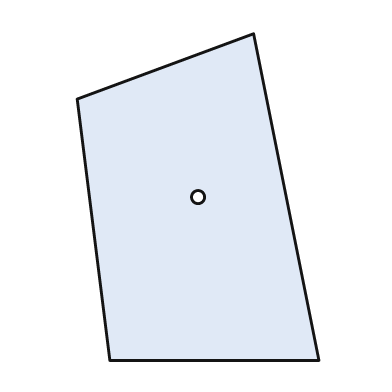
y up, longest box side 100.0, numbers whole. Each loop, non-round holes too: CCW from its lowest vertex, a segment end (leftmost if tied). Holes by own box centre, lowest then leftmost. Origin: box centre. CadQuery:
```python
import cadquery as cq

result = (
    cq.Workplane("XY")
    .moveTo(-27.0, -50.0)
    .lineTo(37.0, -50.0)
    .lineTo(17.0, 50.0)
    .lineTo(-37.0, 30.0)
    .close()
    .moveTo(0.0, 0.0)
    .circle(2.0)
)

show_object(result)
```